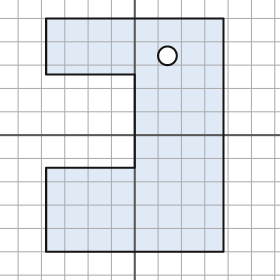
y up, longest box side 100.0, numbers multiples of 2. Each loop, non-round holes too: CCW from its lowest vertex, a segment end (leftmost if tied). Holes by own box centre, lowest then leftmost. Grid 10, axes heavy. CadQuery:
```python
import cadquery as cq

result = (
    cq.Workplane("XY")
    .moveTo(-38.0, -50.0)
    .lineTo(38.0, -50.0)
    .lineTo(38.0, 50.0)
    .lineTo(-38.0, 50.0)
    .lineTo(-38.0, 26.0)
    .lineTo(0.0, 26.0)
    .lineTo(0.0, -14.0)
    .lineTo(-38.0, -14.0)
    .close()
    .moveTo(14.0, 34.0)
    .circle(4.0)
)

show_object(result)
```